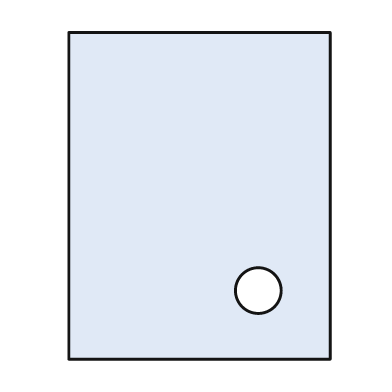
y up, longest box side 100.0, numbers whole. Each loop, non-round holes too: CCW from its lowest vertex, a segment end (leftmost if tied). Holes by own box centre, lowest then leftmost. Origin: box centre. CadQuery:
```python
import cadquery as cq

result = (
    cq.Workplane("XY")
    .moveTo(-40.0, -50.0)
    .lineTo(40.0, -50.0)
    .lineTo(40.0, 50.0)
    .lineTo(-40.0, 50.0)
    .close()
    .moveTo(18.0, -29.0)
    .circle(7.0)
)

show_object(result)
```